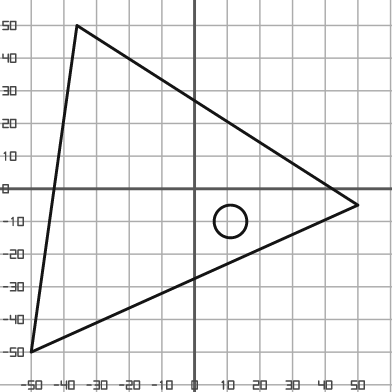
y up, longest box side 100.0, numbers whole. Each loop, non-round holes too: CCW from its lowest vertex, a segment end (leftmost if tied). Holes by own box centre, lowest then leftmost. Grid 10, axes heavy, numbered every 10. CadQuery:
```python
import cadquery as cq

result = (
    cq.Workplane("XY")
    .moveTo(-50.0, -50.0)
    .lineTo(50.0, -5.0)
    .lineTo(-36.0, 50.0)
    .close()
    .moveTo(11.0, -10.0)
    .circle(5.0)
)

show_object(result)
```